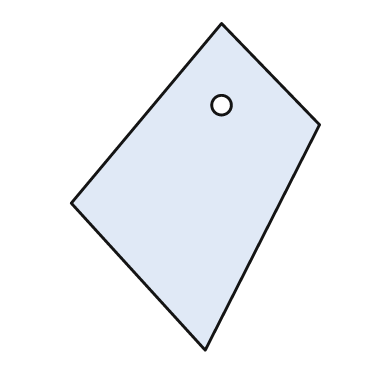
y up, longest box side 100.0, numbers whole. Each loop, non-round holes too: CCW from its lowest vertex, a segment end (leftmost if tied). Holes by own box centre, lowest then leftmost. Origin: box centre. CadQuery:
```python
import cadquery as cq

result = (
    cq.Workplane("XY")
    .moveTo(3.0, -50.0)
    .lineTo(38.0, 19.0)
    .lineTo(8.0, 50.0)
    .lineTo(-38.0, -5.0)
    .close()
    .moveTo(8.0, 25.0)
    .circle(3.0)
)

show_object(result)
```